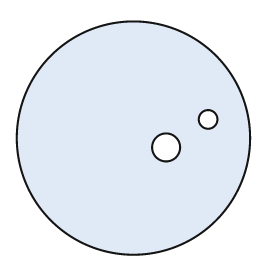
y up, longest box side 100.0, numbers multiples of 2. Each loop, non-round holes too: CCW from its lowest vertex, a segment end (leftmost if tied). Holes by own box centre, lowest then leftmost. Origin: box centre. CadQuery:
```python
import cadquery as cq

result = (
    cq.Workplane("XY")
    .moveTo(0.0, 0.0)
    .circle(50.0)
    .moveTo(14.0, -4.0)
    .circle(6.0)
    .moveTo(32.0, 8.0)
    .circle(4.0)
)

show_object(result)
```